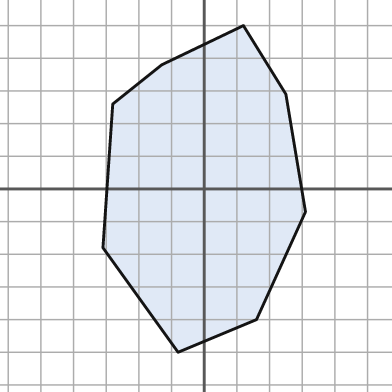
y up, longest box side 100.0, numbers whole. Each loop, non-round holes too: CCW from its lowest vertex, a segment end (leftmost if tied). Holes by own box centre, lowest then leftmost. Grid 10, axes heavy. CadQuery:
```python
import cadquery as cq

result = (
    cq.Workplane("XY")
    .moveTo(-8.0, -50.0)
    .lineTo(16.0, -40.0)
    .lineTo(31.0, -7.0)
    .lineTo(25.0, 29.0)
    .lineTo(12.0, 50.0)
    .lineTo(-13.0, 38.0)
    .lineTo(-28.0, 26.0)
    .lineTo(-31.0, -18.0)
    .close()
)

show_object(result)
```